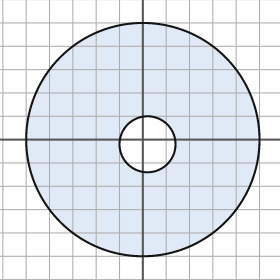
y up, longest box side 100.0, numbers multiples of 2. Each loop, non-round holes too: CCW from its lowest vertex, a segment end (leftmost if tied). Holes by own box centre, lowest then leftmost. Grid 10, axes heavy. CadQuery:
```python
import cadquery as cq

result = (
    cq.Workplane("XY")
    .moveTo(0.0, 0.0)
    .circle(50.0)
    .moveTo(2.0, -2.0)
    .circle(12.0)
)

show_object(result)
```